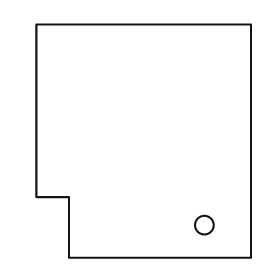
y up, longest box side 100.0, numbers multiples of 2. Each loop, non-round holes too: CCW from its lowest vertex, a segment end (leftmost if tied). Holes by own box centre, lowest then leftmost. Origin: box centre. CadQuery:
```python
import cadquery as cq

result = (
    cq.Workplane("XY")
    .moveTo(-32.0, -50.0)
    .lineTo(46.0, -50.0)
    .lineTo(46.0, 50.0)
    .lineTo(-46.0, 50.0)
    .lineTo(-46.0, -24.0)
    .lineTo(-32.0, -24.0)
    .close()
    .moveTo(26.0, -36.0)
    .circle(4.0)
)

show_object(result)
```